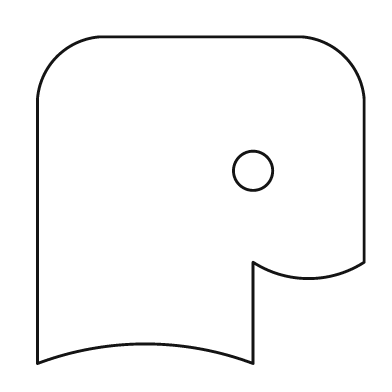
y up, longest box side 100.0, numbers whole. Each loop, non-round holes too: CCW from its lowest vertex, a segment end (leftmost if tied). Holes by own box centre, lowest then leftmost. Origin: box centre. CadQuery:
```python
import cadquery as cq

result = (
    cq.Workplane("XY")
    .moveTo(-50.0, -50.0)
    .threePointArc((-17.0, -44.0), (16.0, -50.0))
    .lineTo(16.0, -19.0)
    .threePointArc((33.0, -24.0), (50.0, -19.0))
    .lineTo(50.0, 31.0)
    .threePointArc((44.0, 44.0), (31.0, 50.0))
    .lineTo(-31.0, 50.0)
    .threePointArc((-44.0, 44.0), (-50.0, 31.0))
    .close()
    .moveTo(16.0, 9.0)
    .circle(6.0)
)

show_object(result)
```